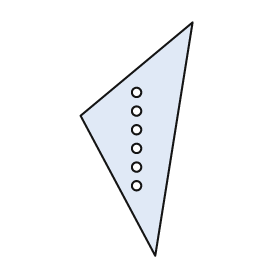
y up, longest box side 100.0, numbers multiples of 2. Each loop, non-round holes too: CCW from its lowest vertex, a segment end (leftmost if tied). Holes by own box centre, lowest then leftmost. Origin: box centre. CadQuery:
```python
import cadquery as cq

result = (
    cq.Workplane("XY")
    .moveTo(8.0, -50.0)
    .lineTo(24.0, 50.0)
    .lineTo(-24.0, 10.0)
    .close()
    .moveTo(0.0, -20.0)
    .circle(2.0)
    .moveTo(0.0, -12.0)
    .circle(2.0)
    .moveTo(0.0, -4.0)
    .circle(2.0)
    .moveTo(0.0, 4.0)
    .circle(2.0)
    .moveTo(0.0, 12.0)
    .circle(2.0)
    .moveTo(0.0, 20.0)
    .circle(2.0)
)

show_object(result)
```